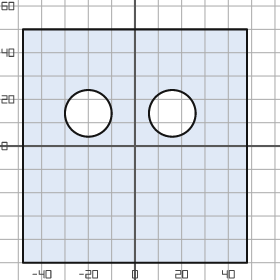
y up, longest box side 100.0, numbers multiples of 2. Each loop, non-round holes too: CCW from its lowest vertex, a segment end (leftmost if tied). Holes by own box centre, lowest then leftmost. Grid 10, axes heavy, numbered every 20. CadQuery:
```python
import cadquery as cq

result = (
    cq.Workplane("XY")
    .moveTo(-48.0, -50.0)
    .lineTo(48.0, -50.0)
    .lineTo(48.0, 50.0)
    .lineTo(-48.0, 50.0)
    .close()
    .moveTo(-20.0, 14.0)
    .circle(10.0)
    .moveTo(16.0, 14.0)
    .circle(10.0)
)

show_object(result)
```